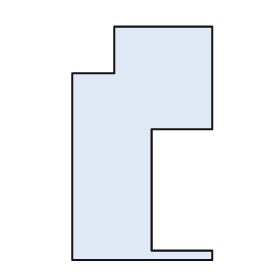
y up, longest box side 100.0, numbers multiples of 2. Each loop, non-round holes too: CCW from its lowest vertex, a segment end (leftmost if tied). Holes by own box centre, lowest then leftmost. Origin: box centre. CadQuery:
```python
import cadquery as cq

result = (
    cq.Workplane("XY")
    .moveTo(-30.0, -50.0)
    .lineTo(30.0, -50.0)
    .lineTo(30.0, -46.0)
    .lineTo(4.0, -46.0)
    .lineTo(4.0, 6.0)
    .lineTo(30.0, 6.0)
    .lineTo(30.0, 50.0)
    .lineTo(-12.0, 50.0)
    .lineTo(-12.0, 30.0)
    .lineTo(-30.0, 30.0)
    .close()
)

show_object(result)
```